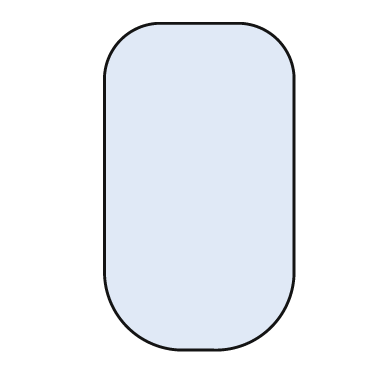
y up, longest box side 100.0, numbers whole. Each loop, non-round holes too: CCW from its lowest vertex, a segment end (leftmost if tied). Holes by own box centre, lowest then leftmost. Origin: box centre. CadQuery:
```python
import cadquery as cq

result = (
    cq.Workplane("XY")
    .moveTo(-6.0, -50.0)
    .lineTo(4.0, -50.0)
    .threePointArc((22.0, -43.0), (29.0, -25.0))
    .lineTo(29.0, 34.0)
    .threePointArc((24.0, 45.0), (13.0, 50.0))
    .lineTo(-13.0, 50.0)
    .threePointArc((-24.0, 45.0), (-29.0, 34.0))
    .lineTo(-29.0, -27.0)
    .threePointArc((-22.0, -43.0), (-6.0, -50.0))
    .close()
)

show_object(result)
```